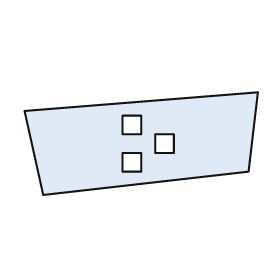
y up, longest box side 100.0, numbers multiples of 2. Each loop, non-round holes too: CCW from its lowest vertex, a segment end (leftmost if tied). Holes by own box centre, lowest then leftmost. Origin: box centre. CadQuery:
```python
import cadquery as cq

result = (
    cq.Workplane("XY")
    .moveTo(-42.0, -22.0)
    .lineTo(46.0, -12.0)
    .lineTo(50.0, 22.0)
    .lineTo(-50.0, 14.0)
    .close()
    .moveTo(-8.0, -12.0)
    .lineTo(0.0, -12.0)
    .lineTo(0.0, -4.0)
    .lineTo(-8.0, -4.0)
    .close()
    .moveTo(6.0, -4.0)
    .lineTo(14.0, -4.0)
    .lineTo(14.0, 4.0)
    .lineTo(6.0, 4.0)
    .close()
    .moveTo(-8.0, 4.0)
    .lineTo(0.0, 4.0)
    .lineTo(0.0, 12.0)
    .lineTo(-8.0, 12.0)
    .close()
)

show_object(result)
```